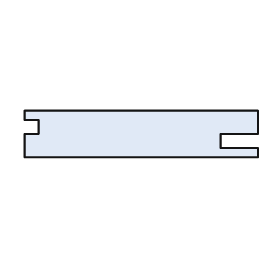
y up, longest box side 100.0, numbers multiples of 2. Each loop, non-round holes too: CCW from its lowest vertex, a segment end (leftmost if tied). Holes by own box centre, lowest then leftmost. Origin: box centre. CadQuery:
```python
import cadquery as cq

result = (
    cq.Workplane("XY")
    .moveTo(-50.0, -10.0)
    .lineTo(50.0, -10.0)
    .lineTo(50.0, -6.0)
    .lineTo(34.0, -6.0)
    .lineTo(34.0, 0.0)
    .lineTo(50.0, 0.0)
    .lineTo(50.0, 10.0)
    .lineTo(-50.0, 10.0)
    .lineTo(-50.0, 6.0)
    .lineTo(-44.0, 6.0)
    .lineTo(-44.0, 0.0)
    .lineTo(-50.0, 0.0)
    .close()
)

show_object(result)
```